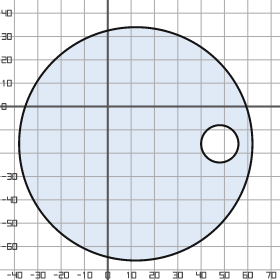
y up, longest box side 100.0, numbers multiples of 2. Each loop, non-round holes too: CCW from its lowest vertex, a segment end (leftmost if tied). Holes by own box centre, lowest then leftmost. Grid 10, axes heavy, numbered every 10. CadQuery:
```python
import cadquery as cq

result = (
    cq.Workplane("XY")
    .moveTo(12.0, -16.0)
    .circle(50.0)
    .moveTo(48.0, -16.0)
    .circle(8.0)
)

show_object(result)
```